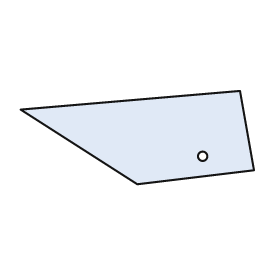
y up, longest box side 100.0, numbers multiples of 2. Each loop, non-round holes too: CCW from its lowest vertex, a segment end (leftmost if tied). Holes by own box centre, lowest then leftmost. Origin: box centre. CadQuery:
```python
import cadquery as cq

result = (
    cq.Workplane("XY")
    .moveTo(0.0, -20.0)
    .lineTo(50.0, -14.0)
    .lineTo(44.0, 20.0)
    .lineTo(-50.0, 12.0)
    .close()
    .moveTo(28.0, -8.0)
    .circle(2.0)
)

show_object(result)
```